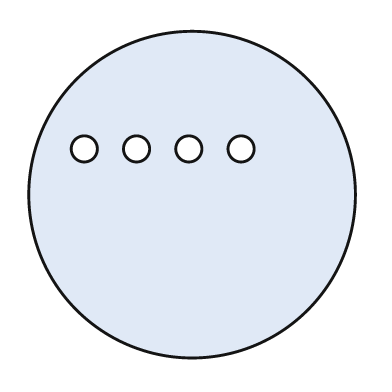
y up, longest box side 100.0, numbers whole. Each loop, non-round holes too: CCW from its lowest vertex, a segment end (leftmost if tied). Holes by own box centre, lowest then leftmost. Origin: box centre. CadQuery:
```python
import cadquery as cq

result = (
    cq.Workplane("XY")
    .moveTo(0.0, 0.0)
    .circle(50.0)
    .moveTo(-33.0, 14.0)
    .circle(4.0)
    .moveTo(-17.0, 14.0)
    .circle(4.0)
    .moveTo(-1.0, 14.0)
    .circle(4.0)
    .moveTo(15.0, 14.0)
    .circle(4.0)
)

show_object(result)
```